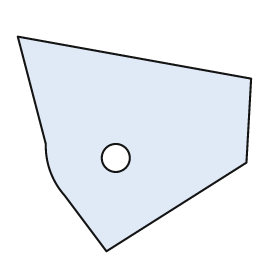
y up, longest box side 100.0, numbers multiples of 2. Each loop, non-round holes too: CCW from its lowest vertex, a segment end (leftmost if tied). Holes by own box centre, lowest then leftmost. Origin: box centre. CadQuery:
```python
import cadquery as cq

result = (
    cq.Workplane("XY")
    .moveTo(-12.0, -46.0)
    .lineTo(48.0, -8.0)
    .lineTo(50.0, 28.0)
    .lineTo(-50.0, 46.0)
    .lineTo(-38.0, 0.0)
    .threePointArc((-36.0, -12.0), (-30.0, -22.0))
    .close()
    .moveTo(-8.0, -6.0)
    .circle(6.0)
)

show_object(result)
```